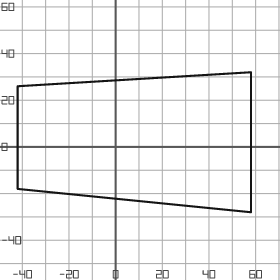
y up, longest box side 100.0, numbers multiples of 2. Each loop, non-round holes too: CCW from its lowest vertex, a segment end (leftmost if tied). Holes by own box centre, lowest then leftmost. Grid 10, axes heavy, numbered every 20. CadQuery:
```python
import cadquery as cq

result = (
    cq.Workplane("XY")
    .moveTo(58.0, -28.0)
    .lineTo(58.0, 32.0)
    .lineTo(-42.0, 26.0)
    .lineTo(-42.0, -18.0)
    .close()
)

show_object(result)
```